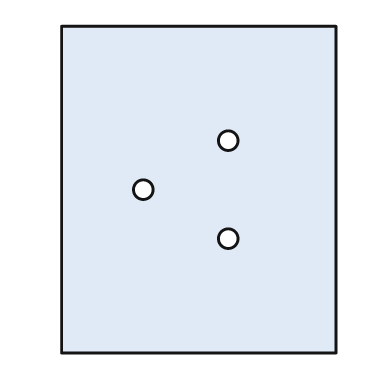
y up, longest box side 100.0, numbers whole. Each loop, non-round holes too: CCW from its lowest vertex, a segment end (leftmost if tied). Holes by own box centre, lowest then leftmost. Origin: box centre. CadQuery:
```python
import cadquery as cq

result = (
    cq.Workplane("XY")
    .moveTo(-42.0, -50.0)
    .lineTo(42.0, -50.0)
    .lineTo(42.0, 50.0)
    .lineTo(-42.0, 50.0)
    .close()
    .moveTo(9.0, -15.0)
    .circle(3.0)
    .moveTo(-17.0, 0.0)
    .circle(3.0)
    .moveTo(9.0, 15.0)
    .circle(3.0)
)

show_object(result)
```